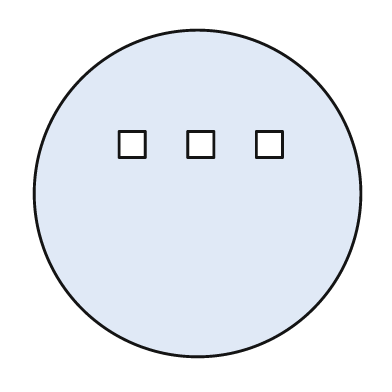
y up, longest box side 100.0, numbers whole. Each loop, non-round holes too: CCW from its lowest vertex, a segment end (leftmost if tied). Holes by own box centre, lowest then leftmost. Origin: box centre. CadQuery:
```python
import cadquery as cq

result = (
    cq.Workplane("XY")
    .moveTo(0.0, 0.0)
    .circle(50.0)
    .moveTo(-24.0, 11.0)
    .lineTo(-16.0, 11.0)
    .lineTo(-16.0, 19.0)
    .lineTo(-24.0, 19.0)
    .close()
    .moveTo(-3.0, 11.0)
    .lineTo(5.0, 11.0)
    .lineTo(5.0, 19.0)
    .lineTo(-3.0, 19.0)
    .close()
    .moveTo(18.0, 11.0)
    .lineTo(26.0, 11.0)
    .lineTo(26.0, 19.0)
    .lineTo(18.0, 19.0)
    .close()
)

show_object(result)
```